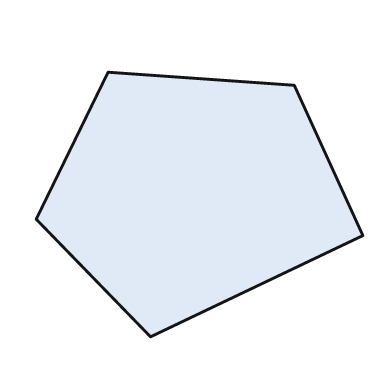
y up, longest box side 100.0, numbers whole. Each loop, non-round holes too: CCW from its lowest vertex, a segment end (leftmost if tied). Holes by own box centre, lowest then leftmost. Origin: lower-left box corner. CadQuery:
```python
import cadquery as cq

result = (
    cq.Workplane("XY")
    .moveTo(35.0, 0.0)
    .lineTo(100.0, 31.0)
    .lineTo(79.0, 77.0)
    .lineTo(22.0, 81.0)
    .lineTo(0.0, 36.0)
    .close()
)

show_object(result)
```